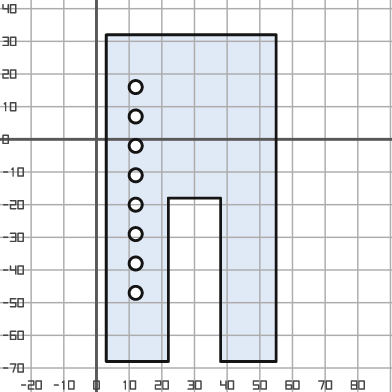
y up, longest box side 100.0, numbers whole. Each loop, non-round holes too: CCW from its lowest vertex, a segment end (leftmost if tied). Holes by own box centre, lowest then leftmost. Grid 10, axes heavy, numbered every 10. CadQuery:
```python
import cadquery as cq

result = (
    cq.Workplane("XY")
    .moveTo(3.0, -68.0)
    .lineTo(22.0, -68.0)
    .lineTo(22.0, -18.0)
    .lineTo(38.0, -18.0)
    .lineTo(38.0, -68.0)
    .lineTo(55.0, -68.0)
    .lineTo(55.0, 32.0)
    .lineTo(3.0, 32.0)
    .close()
    .moveTo(12.0, -47.0)
    .circle(2.0)
    .moveTo(12.0, -38.0)
    .circle(2.0)
    .moveTo(12.0, -29.0)
    .circle(2.0)
    .moveTo(12.0, -20.0)
    .circle(2.0)
    .moveTo(12.0, -11.0)
    .circle(2.0)
    .moveTo(12.0, -2.0)
    .circle(2.0)
    .moveTo(12.0, 7.0)
    .circle(2.0)
    .moveTo(12.0, 16.0)
    .circle(2.0)
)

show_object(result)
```